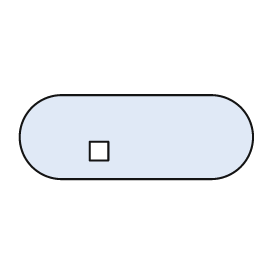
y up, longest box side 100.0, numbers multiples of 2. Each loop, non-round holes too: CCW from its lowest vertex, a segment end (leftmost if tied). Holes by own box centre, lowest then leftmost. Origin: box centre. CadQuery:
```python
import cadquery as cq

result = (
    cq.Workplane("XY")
    .moveTo(-32.0, -18.0)
    .lineTo(32.0, -18.0)
    .threePointArc((50.0, 0.0), (32.0, 18.0))
    .lineTo(-32.0, 18.0)
    .threePointArc((-50.0, 0.0), (-32.0, -18.0))
    .close()
    .moveTo(-20.0, -10.0)
    .lineTo(-12.0, -10.0)
    .lineTo(-12.0, -2.0)
    .lineTo(-20.0, -2.0)
    .close()
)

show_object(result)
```